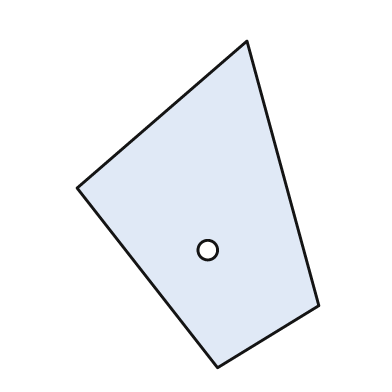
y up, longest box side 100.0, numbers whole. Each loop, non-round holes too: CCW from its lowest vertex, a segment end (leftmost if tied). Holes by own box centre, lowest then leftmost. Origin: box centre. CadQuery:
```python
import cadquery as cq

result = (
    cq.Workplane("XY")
    .moveTo(6.0, -50.0)
    .lineTo(37.0, -31.0)
    .lineTo(15.0, 50.0)
    .lineTo(-37.0, 5.0)
    .close()
    .moveTo(3.0, -14.0)
    .circle(3.0)
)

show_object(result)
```